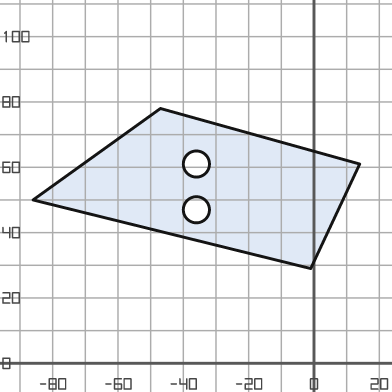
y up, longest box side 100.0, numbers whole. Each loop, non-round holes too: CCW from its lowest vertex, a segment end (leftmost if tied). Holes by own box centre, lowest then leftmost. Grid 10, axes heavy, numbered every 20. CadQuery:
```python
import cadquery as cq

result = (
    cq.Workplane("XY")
    .moveTo(-1.0, 29.0)
    .lineTo(14.0, 61.0)
    .lineTo(-47.0, 78.0)
    .lineTo(-86.0, 50.0)
    .close()
    .moveTo(-36.0, 47.0)
    .circle(4.0)
    .moveTo(-36.0, 61.0)
    .circle(4.0)
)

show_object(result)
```